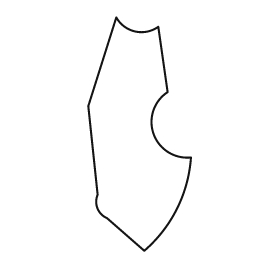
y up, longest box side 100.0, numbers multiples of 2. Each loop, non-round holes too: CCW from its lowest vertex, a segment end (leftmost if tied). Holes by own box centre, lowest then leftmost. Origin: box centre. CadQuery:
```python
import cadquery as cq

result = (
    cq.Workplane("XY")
    .moveTo(2.0, -50.0)
    .threePointArc((16.0, -32.0), (22.0, -10.0))
    .threePointArc((6.0, 0.0), (12.0, 18.0))
    .lineTo(8.0, 46.0)
    .threePointArc((-2.0, 44.0), (-10.0, 50.0))
    .lineTo(-22.0, 12.0)
    .lineTo(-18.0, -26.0)
    .threePointArc((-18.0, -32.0), (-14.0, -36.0))
    .close()
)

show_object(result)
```